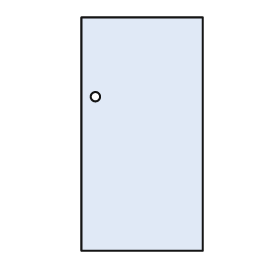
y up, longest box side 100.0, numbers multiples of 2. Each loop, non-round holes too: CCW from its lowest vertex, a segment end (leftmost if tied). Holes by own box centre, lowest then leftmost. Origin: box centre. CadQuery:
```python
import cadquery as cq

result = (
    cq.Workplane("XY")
    .moveTo(-26.0, -50.0)
    .lineTo(26.0, -50.0)
    .lineTo(26.0, 50.0)
    .lineTo(-26.0, 50.0)
    .close()
    .moveTo(-20.0, 16.0)
    .circle(2.0)
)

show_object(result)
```